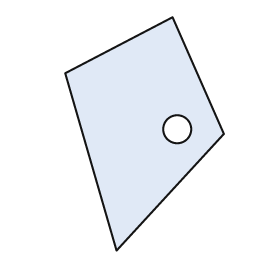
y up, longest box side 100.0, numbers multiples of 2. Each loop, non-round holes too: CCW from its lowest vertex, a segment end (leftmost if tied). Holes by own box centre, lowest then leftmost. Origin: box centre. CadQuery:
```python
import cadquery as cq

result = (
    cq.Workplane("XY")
    .moveTo(-12.0, -50.0)
    .lineTo(34.0, 0.0)
    .lineTo(12.0, 50.0)
    .lineTo(-34.0, 26.0)
    .close()
    .moveTo(14.0, 2.0)
    .circle(6.0)
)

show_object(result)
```